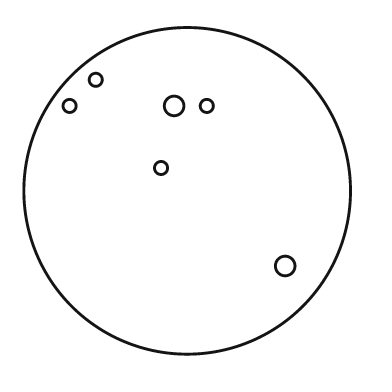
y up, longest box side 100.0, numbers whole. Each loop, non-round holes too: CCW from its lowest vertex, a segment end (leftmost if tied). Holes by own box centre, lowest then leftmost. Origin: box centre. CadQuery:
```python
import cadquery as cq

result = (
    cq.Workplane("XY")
    .moveTo(0.0, 0.0)
    .circle(50.0)
    .moveTo(30.0, -23.0)
    .circle(3.0)
    .moveTo(-8.0, 7.0)
    .circle(2.0)
    .moveTo(-36.0, 26.0)
    .circle(2.0)
    .moveTo(-4.0, 26.0)
    .circle(3.0)
    .moveTo(6.0, 26.0)
    .circle(2.0)
    .moveTo(-28.0, 34.0)
    .circle(2.0)
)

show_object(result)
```